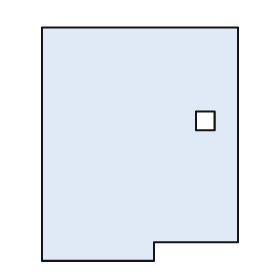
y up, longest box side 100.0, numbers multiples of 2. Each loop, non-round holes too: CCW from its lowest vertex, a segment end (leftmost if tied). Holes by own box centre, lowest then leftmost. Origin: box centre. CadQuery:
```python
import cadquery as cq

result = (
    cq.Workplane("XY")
    .moveTo(-42.0, -50.0)
    .lineTo(6.0, -50.0)
    .lineTo(6.0, -42.0)
    .lineTo(42.0, -42.0)
    .lineTo(42.0, 50.0)
    .lineTo(-42.0, 50.0)
    .close()
    .moveTo(24.0, 6.0)
    .lineTo(32.0, 6.0)
    .lineTo(32.0, 14.0)
    .lineTo(24.0, 14.0)
    .close()
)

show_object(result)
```